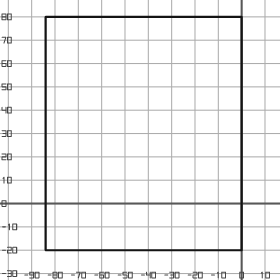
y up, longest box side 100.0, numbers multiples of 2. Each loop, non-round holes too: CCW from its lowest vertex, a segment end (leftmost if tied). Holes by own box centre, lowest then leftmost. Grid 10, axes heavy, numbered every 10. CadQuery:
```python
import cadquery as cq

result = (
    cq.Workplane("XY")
    .moveTo(-84.0, -20.0)
    .lineTo(0.0, -20.0)
    .lineTo(0.0, 80.0)
    .lineTo(-84.0, 80.0)
    .close()
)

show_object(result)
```